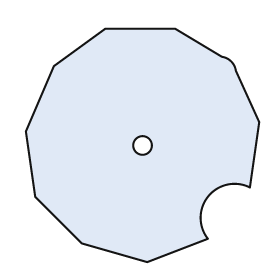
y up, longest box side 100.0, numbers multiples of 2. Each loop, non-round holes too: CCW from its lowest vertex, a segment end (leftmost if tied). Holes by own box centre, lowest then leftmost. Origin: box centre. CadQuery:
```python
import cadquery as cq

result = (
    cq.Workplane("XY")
    .moveTo(2.0, -50.0)
    .lineTo(28.0, -40.0)
    .threePointArc((28.0, -22.0), (46.0, -18.0))
    .lineTo(50.0, 10.0)
    .lineTo(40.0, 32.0)
    .threePointArc((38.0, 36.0), (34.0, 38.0))
    .lineTo(14.0, 50.0)
    .lineTo(-16.0, 50.0)
    .lineTo(-38.0, 34.0)
    .lineTo(-50.0, 6.0)
    .lineTo(-46.0, -22.0)
    .lineTo(-26.0, -42.0)
    .close()
    .moveTo(0.0, 0.0)
    .circle(4.0)
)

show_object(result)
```